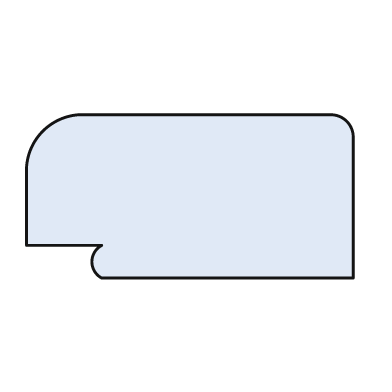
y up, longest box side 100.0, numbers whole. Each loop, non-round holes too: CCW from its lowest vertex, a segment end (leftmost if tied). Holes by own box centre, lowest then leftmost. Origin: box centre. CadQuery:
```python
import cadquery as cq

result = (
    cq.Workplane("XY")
    .moveTo(-27.0, -25.0)
    .lineTo(50.0, -25.0)
    .lineTo(50.0, 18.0)
    .threePointArc((48.0, 23.0), (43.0, 25.0))
    .lineTo(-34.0, 25.0)
    .threePointArc((-45.0, 20.0), (-50.0, 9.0))
    .lineTo(-50.0, -15.0)
    .lineTo(-27.0, -15.0)
    .threePointArc((-30.0, -20.0), (-27.0, -25.0))
    .close()
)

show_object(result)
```